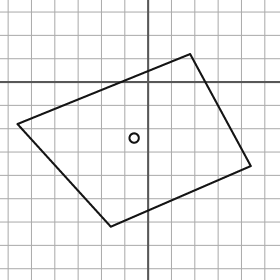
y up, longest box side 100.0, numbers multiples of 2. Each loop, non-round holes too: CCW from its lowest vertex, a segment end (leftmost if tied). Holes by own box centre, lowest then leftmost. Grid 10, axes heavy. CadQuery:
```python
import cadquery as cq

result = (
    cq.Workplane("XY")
    .moveTo(-16.0, -62.0)
    .lineTo(44.0, -36.0)
    .lineTo(18.0, 12.0)
    .lineTo(-56.0, -18.0)
    .close()
    .moveTo(-6.0, -24.0)
    .circle(2.0)
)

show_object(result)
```